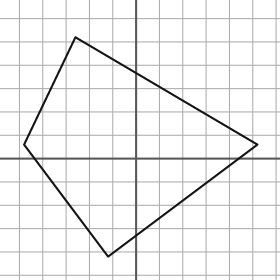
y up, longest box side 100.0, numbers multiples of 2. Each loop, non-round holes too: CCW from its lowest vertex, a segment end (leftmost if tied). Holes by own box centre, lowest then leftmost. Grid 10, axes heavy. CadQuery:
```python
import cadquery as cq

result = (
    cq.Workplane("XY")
    .moveTo(-12.0, -42.0)
    .lineTo(52.0, 6.0)
    .lineTo(-26.0, 52.0)
    .lineTo(-48.0, 6.0)
    .close()
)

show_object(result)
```